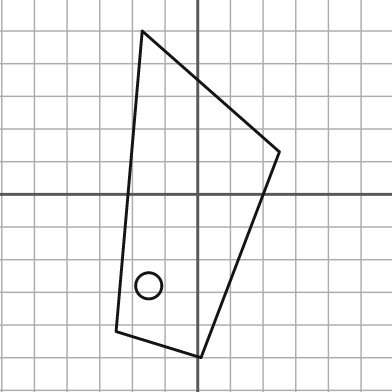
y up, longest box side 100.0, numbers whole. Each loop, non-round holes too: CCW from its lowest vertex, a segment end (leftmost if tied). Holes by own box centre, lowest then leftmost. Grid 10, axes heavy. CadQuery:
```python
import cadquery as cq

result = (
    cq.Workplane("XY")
    .moveTo(1.0, -50.0)
    .lineTo(25.0, 13.0)
    .lineTo(-17.0, 50.0)
    .lineTo(-25.0, -42.0)
    .close()
    .moveTo(-15.0, -28.0)
    .circle(4.0)
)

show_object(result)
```